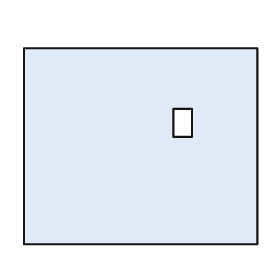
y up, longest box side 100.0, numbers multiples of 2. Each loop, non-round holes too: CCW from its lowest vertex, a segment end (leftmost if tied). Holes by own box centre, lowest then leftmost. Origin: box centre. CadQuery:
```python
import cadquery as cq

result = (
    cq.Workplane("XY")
    .moveTo(-50.0, -42.0)
    .lineTo(50.0, -42.0)
    .lineTo(50.0, 42.0)
    .lineTo(-50.0, 42.0)
    .close()
    .moveTo(14.0, 4.0)
    .lineTo(22.0, 4.0)
    .lineTo(22.0, 16.0)
    .lineTo(14.0, 16.0)
    .close()
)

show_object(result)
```